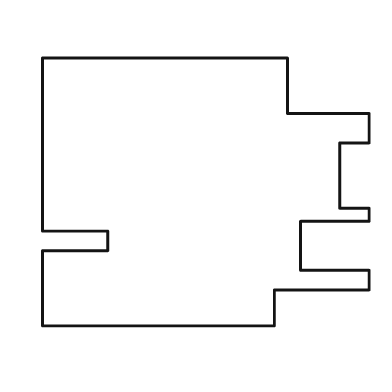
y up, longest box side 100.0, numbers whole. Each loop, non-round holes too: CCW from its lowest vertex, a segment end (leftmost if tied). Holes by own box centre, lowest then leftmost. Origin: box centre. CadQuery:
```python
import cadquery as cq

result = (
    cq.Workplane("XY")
    .moveTo(-50.0, -41.0)
    .lineTo(21.0, -41.0)
    .lineTo(21.0, -30.0)
    .lineTo(50.0, -30.0)
    .lineTo(50.0, -24.0)
    .lineTo(29.0, -24.0)
    .lineTo(29.0, -9.0)
    .lineTo(50.0, -9.0)
    .lineTo(50.0, -5.0)
    .lineTo(41.0, -5.0)
    .lineTo(41.0, 15.0)
    .lineTo(50.0, 15.0)
    .lineTo(50.0, 24.0)
    .lineTo(25.0, 24.0)
    .lineTo(25.0, 41.0)
    .lineTo(-50.0, 41.0)
    .lineTo(-50.0, -12.0)
    .lineTo(-30.0, -12.0)
    .lineTo(-30.0, -18.0)
    .lineTo(-50.0, -18.0)
    .close()
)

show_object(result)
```